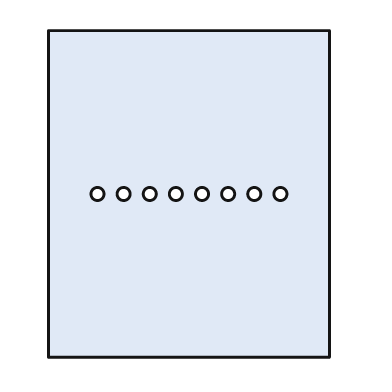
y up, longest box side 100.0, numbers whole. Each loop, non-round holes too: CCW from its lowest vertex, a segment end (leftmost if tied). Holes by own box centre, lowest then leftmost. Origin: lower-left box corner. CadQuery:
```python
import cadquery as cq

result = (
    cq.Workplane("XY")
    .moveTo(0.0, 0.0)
    .lineTo(86.0, 0.0)
    .lineTo(86.0, 100.0)
    .lineTo(0.0, 100.0)
    .close()
    .moveTo(15.0, 50.0)
    .circle(2.0)
    .moveTo(23.0, 50.0)
    .circle(2.0)
    .moveTo(31.0, 50.0)
    .circle(2.0)
    .moveTo(39.0, 50.0)
    .circle(2.0)
    .moveTo(47.0, 50.0)
    .circle(2.0)
    .moveTo(55.0, 50.0)
    .circle(2.0)
    .moveTo(63.0, 50.0)
    .circle(2.0)
    .moveTo(71.0, 50.0)
    .circle(2.0)
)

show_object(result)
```